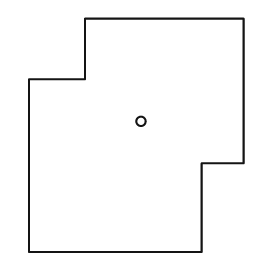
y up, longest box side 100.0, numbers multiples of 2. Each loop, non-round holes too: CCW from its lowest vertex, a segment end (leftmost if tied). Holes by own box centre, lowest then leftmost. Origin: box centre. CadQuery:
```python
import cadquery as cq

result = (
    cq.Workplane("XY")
    .moveTo(-46.0, -50.0)
    .lineTo(28.0, -50.0)
    .lineTo(28.0, -12.0)
    .lineTo(46.0, -12.0)
    .lineTo(46.0, 50.0)
    .lineTo(-22.0, 50.0)
    .lineTo(-22.0, 24.0)
    .lineTo(-46.0, 24.0)
    .close()
    .moveTo(2.0, 6.0)
    .circle(2.0)
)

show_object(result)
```